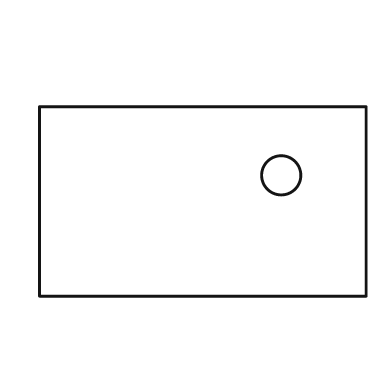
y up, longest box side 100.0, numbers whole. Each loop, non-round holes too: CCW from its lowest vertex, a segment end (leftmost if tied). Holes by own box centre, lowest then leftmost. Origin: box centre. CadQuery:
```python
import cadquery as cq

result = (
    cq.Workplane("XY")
    .moveTo(-50.0, -29.0)
    .lineTo(50.0, -29.0)
    .lineTo(50.0, 29.0)
    .lineTo(-50.0, 29.0)
    .close()
    .moveTo(24.0, 8.0)
    .circle(6.0)
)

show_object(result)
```